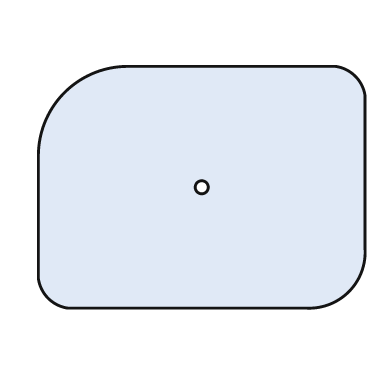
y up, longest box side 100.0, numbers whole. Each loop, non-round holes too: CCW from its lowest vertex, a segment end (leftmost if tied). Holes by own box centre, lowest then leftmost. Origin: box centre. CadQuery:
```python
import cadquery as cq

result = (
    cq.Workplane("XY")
    .moveTo(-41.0, -37.0)
    .lineTo(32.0, -37.0)
    .threePointArc((45.0, -32.0), (50.0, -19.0))
    .lineTo(50.0, 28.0)
    .threePointArc((47.0, 34.0), (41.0, 37.0))
    .lineTo(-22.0, 37.0)
    .threePointArc((-42.0, 29.0), (-50.0, 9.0))
    .lineTo(-50.0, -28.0)
    .threePointArc((-47.0, -34.0), (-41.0, -37.0))
    .close()
    .moveTo(0.0, 0.0)
    .circle(2.0)
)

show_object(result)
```